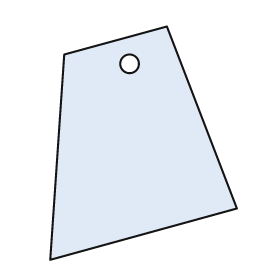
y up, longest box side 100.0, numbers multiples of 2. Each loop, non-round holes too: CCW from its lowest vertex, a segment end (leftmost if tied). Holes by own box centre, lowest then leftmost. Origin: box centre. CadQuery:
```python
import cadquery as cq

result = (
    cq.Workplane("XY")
    .moveTo(-40.0, -50.0)
    .lineTo(40.0, -28.0)
    .lineTo(10.0, 50.0)
    .lineTo(-34.0, 38.0)
    .close()
    .moveTo(-6.0, 34.0)
    .circle(4.0)
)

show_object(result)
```